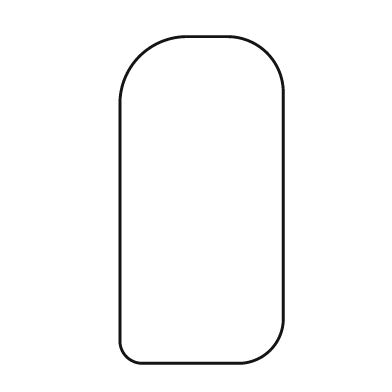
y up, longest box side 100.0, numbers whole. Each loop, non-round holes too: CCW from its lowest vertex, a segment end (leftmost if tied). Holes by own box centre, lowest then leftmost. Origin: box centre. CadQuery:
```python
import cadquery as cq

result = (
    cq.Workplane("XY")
    .moveTo(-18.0, -50.0)
    .lineTo(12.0, -50.0)
    .threePointArc((21.0, -46.0), (25.0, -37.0))
    .lineTo(25.0, 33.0)
    .threePointArc((20.0, 45.0), (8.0, 50.0))
    .lineTo(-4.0, 50.0)
    .threePointArc((-19.0, 44.0), (-25.0, 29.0))
    .lineTo(-25.0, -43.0)
    .threePointArc((-23.0, -48.0), (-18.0, -50.0))
    .close()
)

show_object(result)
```